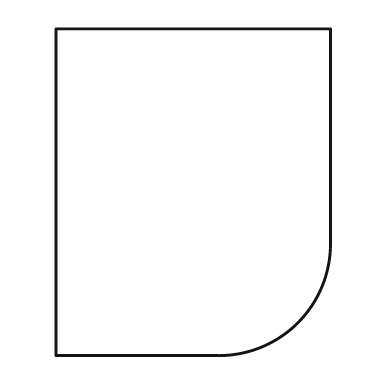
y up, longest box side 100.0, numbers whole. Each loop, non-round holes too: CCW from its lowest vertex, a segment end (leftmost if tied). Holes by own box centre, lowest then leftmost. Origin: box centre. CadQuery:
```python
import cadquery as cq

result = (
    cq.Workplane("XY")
    .moveTo(-42.0, -50.0)
    .lineTo(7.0, -50.0)
    .threePointArc((32.0, -40.0), (42.0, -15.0))
    .lineTo(42.0, 50.0)
    .lineTo(-42.0, 50.0)
    .close()
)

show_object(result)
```